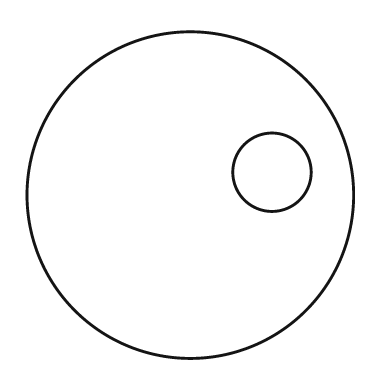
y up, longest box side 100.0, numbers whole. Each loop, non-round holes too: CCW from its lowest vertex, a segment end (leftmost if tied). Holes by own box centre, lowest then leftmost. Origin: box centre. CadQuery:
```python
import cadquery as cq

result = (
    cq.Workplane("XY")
    .moveTo(0.0, 0.0)
    .circle(50.0)
    .moveTo(25.0, 7.0)
    .circle(12.0)
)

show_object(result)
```